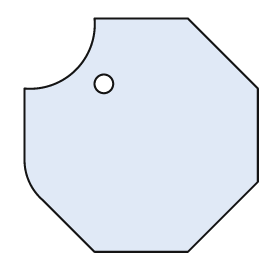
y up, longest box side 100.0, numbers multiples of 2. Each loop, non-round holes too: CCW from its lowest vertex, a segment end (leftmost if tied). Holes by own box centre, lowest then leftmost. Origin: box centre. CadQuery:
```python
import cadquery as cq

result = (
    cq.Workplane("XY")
    .moveTo(-20.0, -50.0)
    .lineTo(20.0, -50.0)
    .lineTo(50.0, -20.0)
    .lineTo(50.0, 20.0)
    .lineTo(20.0, 50.0)
    .lineTo(-20.0, 50.0)
    .threePointArc((-28.0, 28.0), (-50.0, 20.0))
    .lineTo(-50.0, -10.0)
    .threePointArc((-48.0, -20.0), (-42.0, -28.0))
    .close()
    .moveTo(-16.0, 22.0)
    .circle(4.0)
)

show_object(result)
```